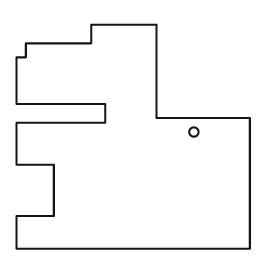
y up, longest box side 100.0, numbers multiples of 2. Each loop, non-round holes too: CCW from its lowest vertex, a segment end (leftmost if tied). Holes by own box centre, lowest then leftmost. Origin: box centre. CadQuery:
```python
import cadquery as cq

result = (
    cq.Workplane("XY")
    .moveTo(-50.0, -48.0)
    .lineTo(50.0, -48.0)
    .lineTo(50.0, 8.0)
    .lineTo(10.0, 8.0)
    .lineTo(10.0, 48.0)
    .lineTo(-18.0, 48.0)
    .lineTo(-18.0, 40.0)
    .lineTo(-46.0, 40.0)
    .lineTo(-46.0, 34.0)
    .lineTo(-50.0, 34.0)
    .lineTo(-50.0, 14.0)
    .lineTo(-12.0, 14.0)
    .lineTo(-12.0, 6.0)
    .lineTo(-50.0, 6.0)
    .lineTo(-50.0, -12.0)
    .lineTo(-34.0, -12.0)
    .lineTo(-34.0, -34.0)
    .lineTo(-50.0, -34.0)
    .close()
    .moveTo(26.0, 2.0)
    .circle(2.0)
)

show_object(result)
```